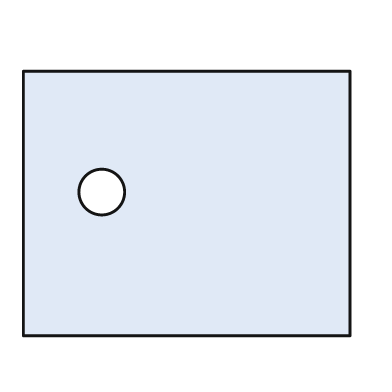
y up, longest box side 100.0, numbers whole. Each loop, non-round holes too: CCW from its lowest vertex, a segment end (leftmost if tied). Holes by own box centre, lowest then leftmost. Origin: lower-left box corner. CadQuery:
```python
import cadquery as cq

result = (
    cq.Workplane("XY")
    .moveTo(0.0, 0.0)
    .lineTo(100.0, 0.0)
    .lineTo(100.0, 81.0)
    .lineTo(0.0, 81.0)
    .close()
    .moveTo(24.0, 44.0)
    .circle(7.0)
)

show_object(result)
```